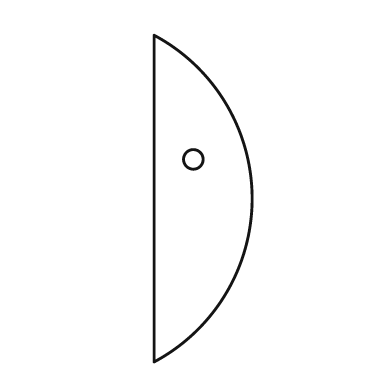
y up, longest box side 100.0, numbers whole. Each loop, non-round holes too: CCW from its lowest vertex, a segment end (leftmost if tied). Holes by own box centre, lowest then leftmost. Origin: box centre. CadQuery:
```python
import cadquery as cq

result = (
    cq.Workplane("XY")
    .moveTo(-15.0, -50.0)
    .threePointArc((15.0, 0.0), (-15.0, 50.0))
    .close()
    .moveTo(-3.0, 12.0)
    .circle(3.0)
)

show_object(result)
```